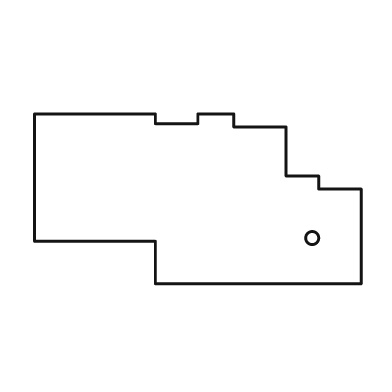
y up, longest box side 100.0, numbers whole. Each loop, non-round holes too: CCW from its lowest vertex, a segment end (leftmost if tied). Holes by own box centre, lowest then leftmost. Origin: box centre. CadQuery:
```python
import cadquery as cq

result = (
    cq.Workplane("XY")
    .moveTo(-13.0, -26.0)
    .lineTo(50.0, -26.0)
    .lineTo(50.0, 3.0)
    .lineTo(37.0, 3.0)
    .lineTo(37.0, 7.0)
    .lineTo(27.0, 7.0)
    .lineTo(27.0, 22.0)
    .lineTo(11.0, 22.0)
    .lineTo(11.0, 26.0)
    .lineTo(0.0, 26.0)
    .lineTo(0.0, 23.0)
    .lineTo(-13.0, 23.0)
    .lineTo(-13.0, 26.0)
    .lineTo(-50.0, 26.0)
    .lineTo(-50.0, -13.0)
    .lineTo(-13.0, -13.0)
    .close()
    .moveTo(35.0, -12.0)
    .circle(2.0)
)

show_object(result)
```